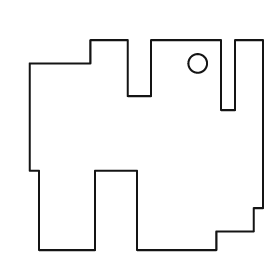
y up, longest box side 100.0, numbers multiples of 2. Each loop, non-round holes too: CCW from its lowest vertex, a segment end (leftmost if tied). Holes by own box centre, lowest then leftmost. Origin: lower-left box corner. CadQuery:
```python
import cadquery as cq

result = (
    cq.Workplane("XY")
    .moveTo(4.0, 0.0)
    .lineTo(28.0, 0.0)
    .lineTo(28.0, 34.0)
    .lineTo(46.0, 34.0)
    .lineTo(46.0, 0.0)
    .lineTo(80.0, 0.0)
    .lineTo(80.0, 8.0)
    .lineTo(96.0, 8.0)
    .lineTo(96.0, 18.0)
    .lineTo(100.0, 18.0)
    .lineTo(100.0, 90.0)
    .lineTo(88.0, 90.0)
    .lineTo(88.0, 60.0)
    .lineTo(82.0, 60.0)
    .lineTo(82.0, 90.0)
    .lineTo(52.0, 90.0)
    .lineTo(52.0, 66.0)
    .lineTo(42.0, 66.0)
    .lineTo(42.0, 90.0)
    .lineTo(26.0, 90.0)
    .lineTo(26.0, 80.0)
    .lineTo(0.0, 80.0)
    .lineTo(0.0, 34.0)
    .lineTo(4.0, 34.0)
    .close()
    .moveTo(72.0, 80.0)
    .circle(4.0)
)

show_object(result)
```